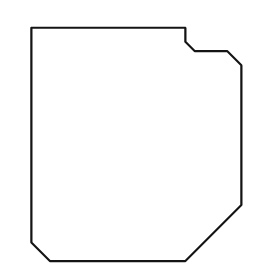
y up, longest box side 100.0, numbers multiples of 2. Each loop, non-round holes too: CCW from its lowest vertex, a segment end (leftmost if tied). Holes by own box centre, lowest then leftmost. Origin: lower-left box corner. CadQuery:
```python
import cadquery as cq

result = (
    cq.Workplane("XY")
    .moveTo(8.0, 0.0)
    .lineTo(66.0, 0.0)
    .lineTo(90.0, 24.0)
    .lineTo(90.0, 84.0)
    .lineTo(84.0, 90.0)
    .lineTo(70.0, 90.0)
    .lineTo(66.0, 94.0)
    .lineTo(66.0, 100.0)
    .lineTo(0.0, 100.0)
    .lineTo(0.0, 8.0)
    .close()
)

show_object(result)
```